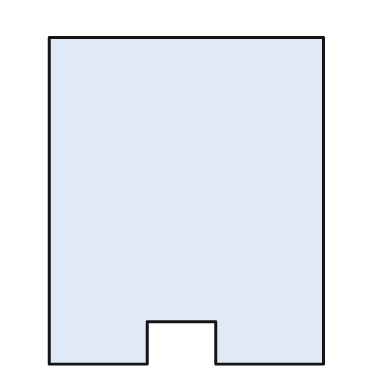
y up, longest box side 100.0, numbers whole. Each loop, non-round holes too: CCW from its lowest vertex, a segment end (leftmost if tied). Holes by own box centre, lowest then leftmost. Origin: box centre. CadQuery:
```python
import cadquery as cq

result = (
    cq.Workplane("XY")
    .moveTo(-42.0, -50.0)
    .lineTo(-12.0, -50.0)
    .lineTo(-12.0, -37.0)
    .lineTo(9.0, -37.0)
    .lineTo(9.0, -50.0)
    .lineTo(42.0, -50.0)
    .lineTo(42.0, 50.0)
    .lineTo(-42.0, 50.0)
    .close()
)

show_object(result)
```